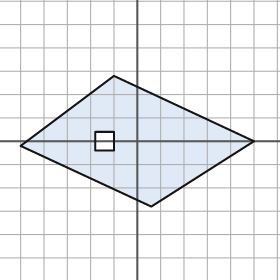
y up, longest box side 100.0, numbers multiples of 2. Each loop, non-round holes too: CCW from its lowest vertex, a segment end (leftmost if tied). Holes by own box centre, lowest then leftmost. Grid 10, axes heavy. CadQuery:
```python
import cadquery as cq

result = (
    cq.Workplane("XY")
    .moveTo(6.0, -28.0)
    .lineTo(50.0, 0.0)
    .lineTo(-10.0, 28.0)
    .lineTo(-50.0, -2.0)
    .close()
    .moveTo(-18.0, -4.0)
    .lineTo(-10.0, -4.0)
    .lineTo(-10.0, 4.0)
    .lineTo(-18.0, 4.0)
    .close()
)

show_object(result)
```